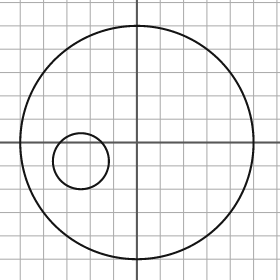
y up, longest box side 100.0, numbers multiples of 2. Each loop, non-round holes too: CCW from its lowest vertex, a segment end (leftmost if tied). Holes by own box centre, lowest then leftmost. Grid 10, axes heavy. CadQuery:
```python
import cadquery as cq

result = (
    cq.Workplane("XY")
    .moveTo(0.0, 0.0)
    .circle(50.0)
    .moveTo(-24.0, -8.0)
    .circle(12.0)
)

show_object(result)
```